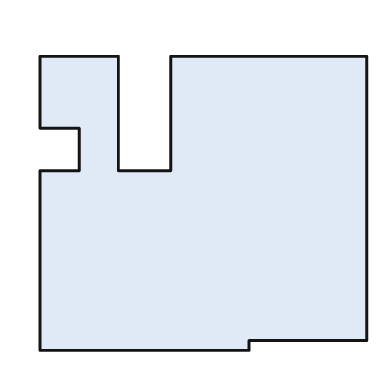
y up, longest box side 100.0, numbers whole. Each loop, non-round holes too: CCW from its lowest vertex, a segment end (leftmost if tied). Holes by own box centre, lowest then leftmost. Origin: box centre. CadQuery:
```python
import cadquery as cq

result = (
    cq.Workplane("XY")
    .moveTo(-50.0, -45.0)
    .lineTo(14.0, -45.0)
    .lineTo(14.0, -42.0)
    .lineTo(50.0, -42.0)
    .lineTo(50.0, 45.0)
    .lineTo(-10.0, 45.0)
    .lineTo(-10.0, 10.0)
    .lineTo(-26.0, 10.0)
    .lineTo(-26.0, 45.0)
    .lineTo(-50.0, 45.0)
    .lineTo(-50.0, 23.0)
    .lineTo(-38.0, 23.0)
    .lineTo(-38.0, 10.0)
    .lineTo(-50.0, 10.0)
    .close()
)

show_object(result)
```